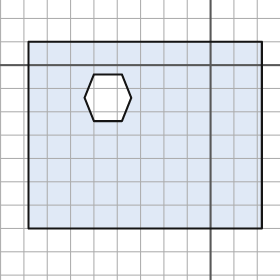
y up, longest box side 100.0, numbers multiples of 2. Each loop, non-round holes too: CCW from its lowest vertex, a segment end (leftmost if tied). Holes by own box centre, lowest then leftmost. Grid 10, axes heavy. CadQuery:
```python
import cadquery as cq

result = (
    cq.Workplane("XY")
    .moveTo(-78.0, -70.0)
    .lineTo(22.0, -70.0)
    .lineTo(22.0, 10.0)
    .lineTo(-78.0, 10.0)
    .close()
    .moveTo(-50.0, -24.0)
    .lineTo(-38.0, -24.0)
    .lineTo(-34.0, -14.0)
    .lineTo(-38.0, -4.0)
    .lineTo(-50.0, -4.0)
    .lineTo(-54.0, -14.0)
    .close()
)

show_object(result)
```